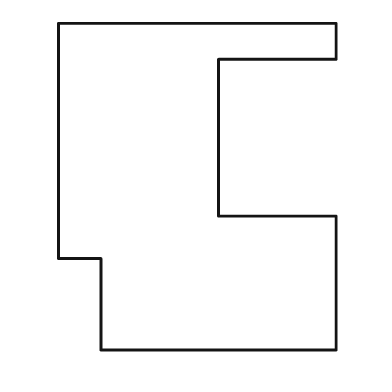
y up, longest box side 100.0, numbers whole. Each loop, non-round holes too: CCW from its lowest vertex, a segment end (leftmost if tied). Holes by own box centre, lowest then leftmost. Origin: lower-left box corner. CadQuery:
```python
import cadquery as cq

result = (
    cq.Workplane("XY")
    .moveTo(13.0, 0.0)
    .lineTo(85.0, 0.0)
    .lineTo(85.0, 41.0)
    .lineTo(49.0, 41.0)
    .lineTo(49.0, 89.0)
    .lineTo(85.0, 89.0)
    .lineTo(85.0, 100.0)
    .lineTo(0.0, 100.0)
    .lineTo(0.0, 28.0)
    .lineTo(13.0, 28.0)
    .close()
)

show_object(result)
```